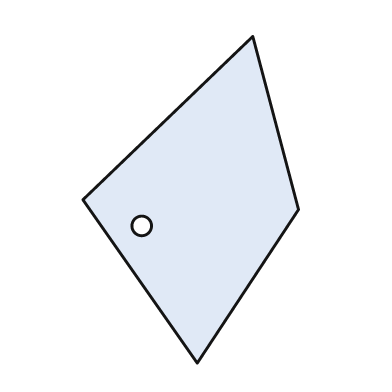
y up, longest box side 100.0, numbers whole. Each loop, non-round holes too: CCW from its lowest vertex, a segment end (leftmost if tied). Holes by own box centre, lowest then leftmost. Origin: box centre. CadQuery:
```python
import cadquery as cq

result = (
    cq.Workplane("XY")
    .moveTo(2.0, -50.0)
    .lineTo(33.0, -3.0)
    .lineTo(19.0, 50.0)
    .lineTo(-33.0, 0.0)
    .close()
    .moveTo(-15.0, -8.0)
    .circle(3.0)
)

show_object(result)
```